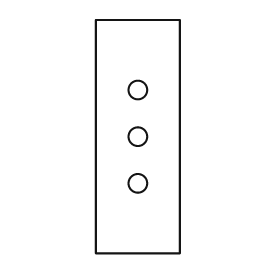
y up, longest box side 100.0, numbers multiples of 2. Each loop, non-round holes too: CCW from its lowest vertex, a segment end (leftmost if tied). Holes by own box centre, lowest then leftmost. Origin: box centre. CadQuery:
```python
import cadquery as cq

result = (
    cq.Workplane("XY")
    .moveTo(-18.0, -50.0)
    .lineTo(18.0, -50.0)
    .lineTo(18.0, 50.0)
    .lineTo(-18.0, 50.0)
    .close()
    .moveTo(0.0, -20.0)
    .circle(4.0)
    .moveTo(0.0, 0.0)
    .circle(4.0)
    .moveTo(0.0, 20.0)
    .circle(4.0)
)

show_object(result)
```